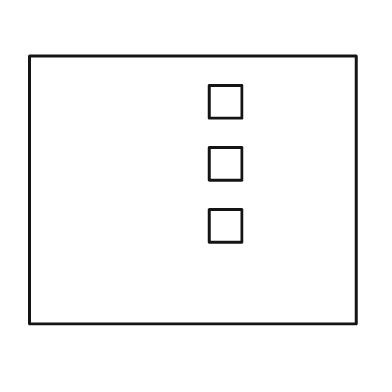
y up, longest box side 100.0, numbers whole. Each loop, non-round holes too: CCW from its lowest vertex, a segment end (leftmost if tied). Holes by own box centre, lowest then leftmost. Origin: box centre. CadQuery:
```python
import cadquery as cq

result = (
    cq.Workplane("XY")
    .moveTo(-50.0, -41.0)
    .lineTo(50.0, -41.0)
    .lineTo(50.0, 41.0)
    .lineTo(-50.0, 41.0)
    .close()
    .moveTo(5.0, -16.0)
    .lineTo(15.0, -16.0)
    .lineTo(15.0, -6.0)
    .lineTo(5.0, -6.0)
    .close()
    .moveTo(5.0, 3.0)
    .lineTo(15.0, 3.0)
    .lineTo(15.0, 13.0)
    .lineTo(5.0, 13.0)
    .close()
    .moveTo(5.0, 22.0)
    .lineTo(15.0, 22.0)
    .lineTo(15.0, 32.0)
    .lineTo(5.0, 32.0)
    .close()
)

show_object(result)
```